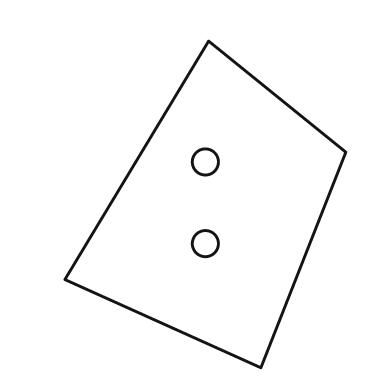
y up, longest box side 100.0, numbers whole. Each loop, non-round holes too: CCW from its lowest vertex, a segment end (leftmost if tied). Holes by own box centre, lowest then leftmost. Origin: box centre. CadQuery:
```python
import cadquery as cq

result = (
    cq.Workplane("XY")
    .moveTo(17.0, -50.0)
    .lineTo(43.0, 16.0)
    .lineTo(1.0, 50.0)
    .lineTo(-43.0, -23.0)
    .close()
    .moveTo(0.0, -12.0)
    .circle(4.0)
    .moveTo(0.0, 13.0)
    .circle(4.0)
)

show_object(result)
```